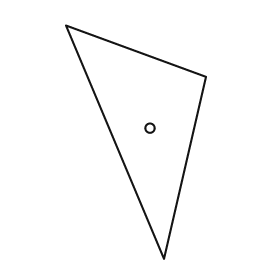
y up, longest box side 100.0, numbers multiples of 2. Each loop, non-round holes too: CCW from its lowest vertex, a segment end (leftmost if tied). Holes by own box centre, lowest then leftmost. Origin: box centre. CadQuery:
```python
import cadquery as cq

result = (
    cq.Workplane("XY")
    .moveTo(12.0, -50.0)
    .lineTo(30.0, 28.0)
    .lineTo(-30.0, 50.0)
    .close()
    .moveTo(6.0, 6.0)
    .circle(2.0)
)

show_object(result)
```